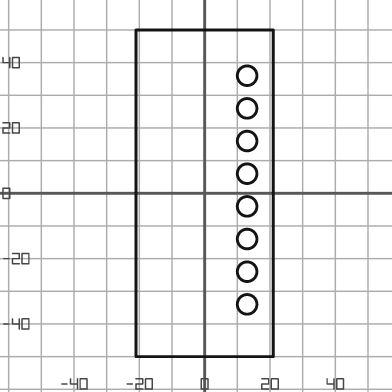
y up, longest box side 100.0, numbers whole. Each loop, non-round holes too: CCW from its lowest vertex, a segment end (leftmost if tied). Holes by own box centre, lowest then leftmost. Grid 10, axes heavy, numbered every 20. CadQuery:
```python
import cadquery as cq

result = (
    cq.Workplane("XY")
    .moveTo(-21.0, -50.0)
    .lineTo(21.0, -50.0)
    .lineTo(21.0, 50.0)
    .lineTo(-21.0, 50.0)
    .close()
    .moveTo(13.0, -34.0)
    .circle(3.0)
    .moveTo(13.0, -24.0)
    .circle(3.0)
    .moveTo(13.0, -14.0)
    .circle(3.0)
    .moveTo(13.0, -4.0)
    .circle(3.0)
    .moveTo(13.0, 6.0)
    .circle(3.0)
    .moveTo(13.0, 16.0)
    .circle(3.0)
    .moveTo(13.0, 26.0)
    .circle(3.0)
    .moveTo(13.0, 36.0)
    .circle(3.0)
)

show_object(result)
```